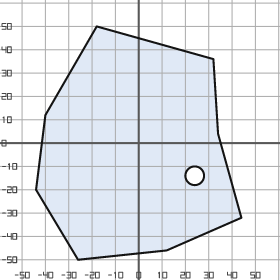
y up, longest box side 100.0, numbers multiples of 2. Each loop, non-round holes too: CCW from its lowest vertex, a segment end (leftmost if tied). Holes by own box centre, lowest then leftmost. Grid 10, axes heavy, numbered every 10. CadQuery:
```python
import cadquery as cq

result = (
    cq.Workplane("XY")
    .moveTo(-26.0, -50.0)
    .lineTo(12.0, -46.0)
    .lineTo(44.0, -32.0)
    .lineTo(34.0, 4.0)
    .lineTo(32.0, 36.0)
    .lineTo(-18.0, 50.0)
    .lineTo(-40.0, 12.0)
    .lineTo(-44.0, -20.0)
    .close()
    .moveTo(24.0, -14.0)
    .circle(4.0)
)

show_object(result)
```